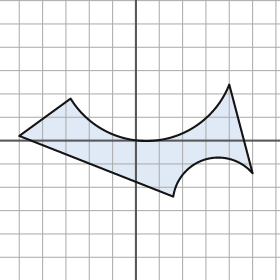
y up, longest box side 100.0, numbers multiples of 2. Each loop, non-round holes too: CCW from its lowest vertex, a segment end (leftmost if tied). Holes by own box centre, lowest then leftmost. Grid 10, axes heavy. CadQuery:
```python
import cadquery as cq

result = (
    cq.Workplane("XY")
    .moveTo(16.0, -24.0)
    .threePointArc((30.0, -8.0), (50.0, -14.0))
    .lineTo(40.0, 24.0)
    .threePointArc((8.0, 0.0), (-28.0, 18.0))
    .lineTo(-50.0, 2.0)
    .close()
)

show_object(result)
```